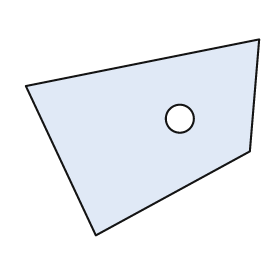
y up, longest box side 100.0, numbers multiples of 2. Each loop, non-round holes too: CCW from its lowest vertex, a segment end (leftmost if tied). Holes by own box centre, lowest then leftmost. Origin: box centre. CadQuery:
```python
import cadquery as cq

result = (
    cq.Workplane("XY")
    .moveTo(-20.0, -42.0)
    .lineTo(46.0, -6.0)
    .lineTo(50.0, 42.0)
    .lineTo(-50.0, 22.0)
    .close()
    .moveTo(16.0, 8.0)
    .circle(6.0)
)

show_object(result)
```